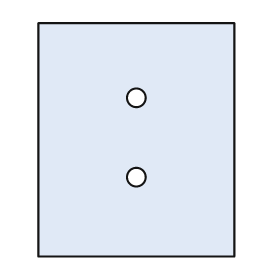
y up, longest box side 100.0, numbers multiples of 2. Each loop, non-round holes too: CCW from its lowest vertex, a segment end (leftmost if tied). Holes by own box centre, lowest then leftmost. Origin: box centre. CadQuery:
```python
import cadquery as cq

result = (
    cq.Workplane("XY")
    .moveTo(-42.0, -50.0)
    .lineTo(42.0, -50.0)
    .lineTo(42.0, 50.0)
    .lineTo(-42.0, 50.0)
    .close()
    .moveTo(0.0, -16.0)
    .circle(4.0)
    .moveTo(0.0, 18.0)
    .circle(4.0)
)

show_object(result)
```